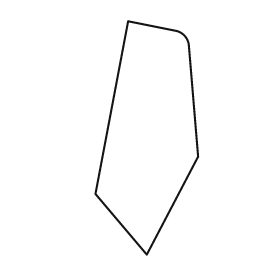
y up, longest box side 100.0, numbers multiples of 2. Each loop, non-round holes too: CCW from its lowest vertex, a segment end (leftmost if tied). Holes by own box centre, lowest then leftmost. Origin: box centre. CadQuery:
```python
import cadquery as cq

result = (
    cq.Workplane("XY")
    .moveTo(0.0, -50.0)
    .lineTo(22.0, -8.0)
    .lineTo(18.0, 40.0)
    .threePointArc((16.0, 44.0), (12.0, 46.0))
    .lineTo(-8.0, 50.0)
    .lineTo(-22.0, -24.0)
    .close()
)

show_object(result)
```